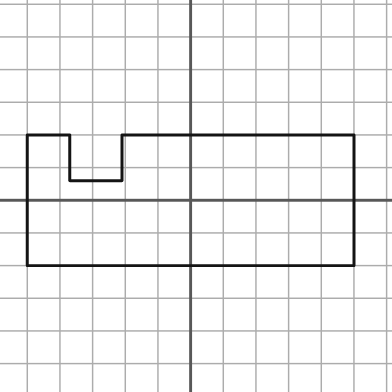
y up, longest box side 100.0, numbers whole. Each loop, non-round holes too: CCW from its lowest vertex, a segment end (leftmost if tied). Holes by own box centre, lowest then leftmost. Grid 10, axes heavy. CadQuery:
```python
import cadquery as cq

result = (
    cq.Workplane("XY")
    .moveTo(-50.0, -20.0)
    .lineTo(50.0, -20.0)
    .lineTo(50.0, 20.0)
    .lineTo(-21.0, 20.0)
    .lineTo(-21.0, 6.0)
    .lineTo(-37.0, 6.0)
    .lineTo(-37.0, 20.0)
    .lineTo(-50.0, 20.0)
    .close()
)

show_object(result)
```